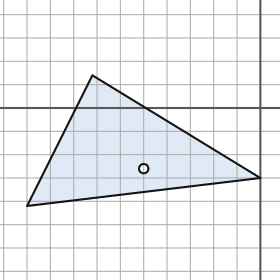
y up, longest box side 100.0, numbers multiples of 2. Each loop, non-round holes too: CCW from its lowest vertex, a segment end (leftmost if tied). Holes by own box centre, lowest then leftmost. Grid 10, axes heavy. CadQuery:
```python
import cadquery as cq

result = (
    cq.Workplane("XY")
    .moveTo(-100.0, -42.0)
    .lineTo(0.0, -30.0)
    .lineTo(-72.0, 14.0)
    .close()
    .moveTo(-50.0, -26.0)
    .circle(2.0)
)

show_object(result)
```